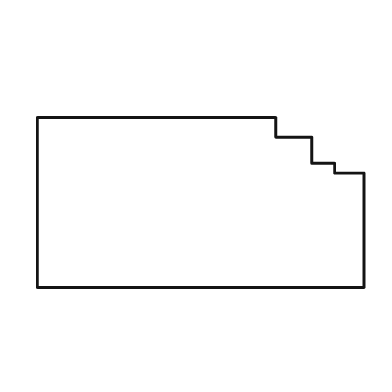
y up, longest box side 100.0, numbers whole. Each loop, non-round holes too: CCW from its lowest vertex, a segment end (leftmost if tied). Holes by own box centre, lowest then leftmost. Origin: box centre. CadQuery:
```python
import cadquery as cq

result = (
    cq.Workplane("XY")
    .moveTo(-50.0, -26.0)
    .lineTo(50.0, -26.0)
    .lineTo(50.0, 9.0)
    .lineTo(41.0, 9.0)
    .lineTo(41.0, 12.0)
    .lineTo(34.0, 12.0)
    .lineTo(34.0, 20.0)
    .lineTo(23.0, 20.0)
    .lineTo(23.0, 26.0)
    .lineTo(-50.0, 26.0)
    .close()
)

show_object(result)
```